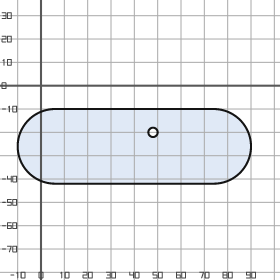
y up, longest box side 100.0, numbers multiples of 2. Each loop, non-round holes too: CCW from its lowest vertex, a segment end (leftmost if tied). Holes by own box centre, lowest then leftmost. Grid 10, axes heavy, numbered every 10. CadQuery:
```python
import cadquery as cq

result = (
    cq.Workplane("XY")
    .moveTo(6.0, -42.0)
    .lineTo(74.0, -42.0)
    .threePointArc((90.0, -26.0), (74.0, -10.0))
    .lineTo(6.0, -10.0)
    .threePointArc((-10.0, -26.0), (6.0, -42.0))
    .close()
    .moveTo(48.0, -20.0)
    .circle(2.0)
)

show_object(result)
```